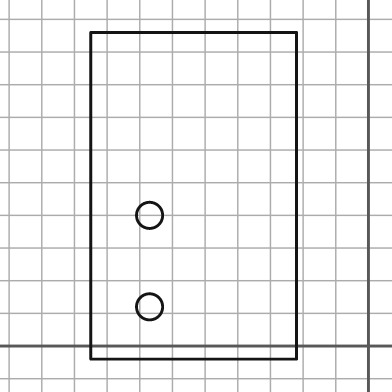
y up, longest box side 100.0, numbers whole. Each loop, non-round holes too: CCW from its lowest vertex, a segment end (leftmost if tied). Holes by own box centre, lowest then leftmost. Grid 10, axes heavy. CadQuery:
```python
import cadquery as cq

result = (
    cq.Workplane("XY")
    .moveTo(-85.0, -4.0)
    .lineTo(-22.0, -4.0)
    .lineTo(-22.0, 96.0)
    .lineTo(-85.0, 96.0)
    .close()
    .moveTo(-67.0, 12.0)
    .circle(4.0)
    .moveTo(-67.0, 40.0)
    .circle(4.0)
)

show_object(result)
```